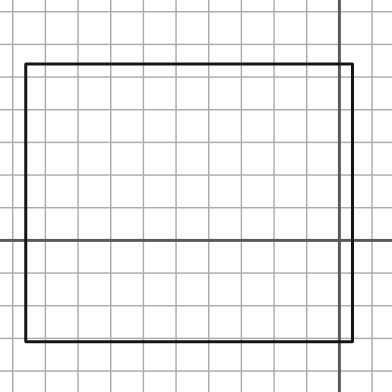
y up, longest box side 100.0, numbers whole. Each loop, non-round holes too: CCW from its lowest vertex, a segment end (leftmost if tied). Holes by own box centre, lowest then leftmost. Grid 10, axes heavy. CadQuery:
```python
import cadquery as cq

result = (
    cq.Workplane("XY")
    .moveTo(-96.0, -31.0)
    .lineTo(4.0, -31.0)
    .lineTo(4.0, 54.0)
    .lineTo(-96.0, 54.0)
    .close()
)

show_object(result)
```